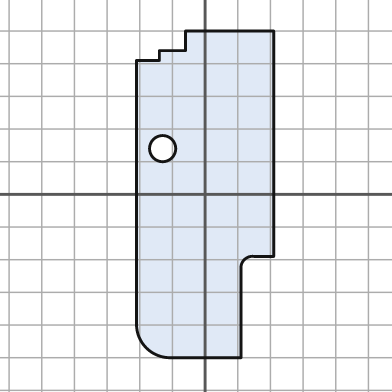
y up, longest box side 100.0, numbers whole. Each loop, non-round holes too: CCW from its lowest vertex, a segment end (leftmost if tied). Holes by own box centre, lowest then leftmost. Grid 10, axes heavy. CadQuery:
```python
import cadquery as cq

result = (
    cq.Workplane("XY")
    .moveTo(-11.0, -50.0)
    .lineTo(11.0, -50.0)
    .lineTo(11.0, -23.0)
    .threePointArc((12.0, -20.0), (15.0, -19.0))
    .lineTo(21.0, -19.0)
    .lineTo(21.0, 50.0)
    .lineTo(-6.0, 50.0)
    .lineTo(-6.0, 44.0)
    .lineTo(-14.0, 44.0)
    .lineTo(-14.0, 41.0)
    .lineTo(-21.0, 41.0)
    .lineTo(-21.0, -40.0)
    .threePointArc((-18.0, -47.0), (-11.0, -50.0))
    .close()
    .moveTo(-13.0, 14.0)
    .circle(4.0)
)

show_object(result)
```